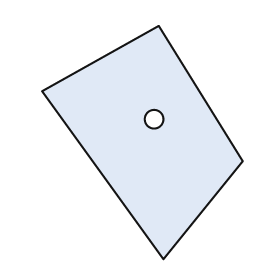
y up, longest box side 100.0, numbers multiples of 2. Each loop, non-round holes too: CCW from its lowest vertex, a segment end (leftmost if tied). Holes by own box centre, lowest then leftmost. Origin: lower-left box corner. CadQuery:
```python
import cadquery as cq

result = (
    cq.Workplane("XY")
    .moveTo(52.0, 0.0)
    .lineTo(86.0, 42.0)
    .lineTo(50.0, 100.0)
    .lineTo(0.0, 72.0)
    .close()
    .moveTo(48.0, 60.0)
    .circle(4.0)
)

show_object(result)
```